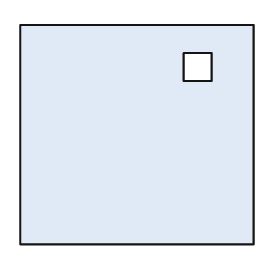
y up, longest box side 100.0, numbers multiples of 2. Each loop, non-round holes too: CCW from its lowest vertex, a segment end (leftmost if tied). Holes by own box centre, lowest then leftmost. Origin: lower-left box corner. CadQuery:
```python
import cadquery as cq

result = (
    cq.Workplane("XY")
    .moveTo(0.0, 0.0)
    .lineTo(100.0, 0.0)
    .lineTo(100.0, 94.0)
    .lineTo(0.0, 94.0)
    .close()
    .moveTo(70.0, 70.0)
    .lineTo(82.0, 70.0)
    .lineTo(82.0, 82.0)
    .lineTo(70.0, 82.0)
    .close()
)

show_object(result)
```